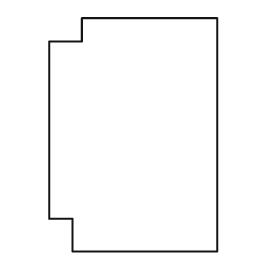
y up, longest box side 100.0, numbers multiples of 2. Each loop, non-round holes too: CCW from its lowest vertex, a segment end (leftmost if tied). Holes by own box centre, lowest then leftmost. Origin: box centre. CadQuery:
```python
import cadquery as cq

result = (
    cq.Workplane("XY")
    .moveTo(-26.0, -50.0)
    .lineTo(36.0, -50.0)
    .lineTo(36.0, 50.0)
    .lineTo(-22.0, 50.0)
    .lineTo(-22.0, 40.0)
    .lineTo(-36.0, 40.0)
    .lineTo(-36.0, -36.0)
    .lineTo(-26.0, -36.0)
    .close()
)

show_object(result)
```